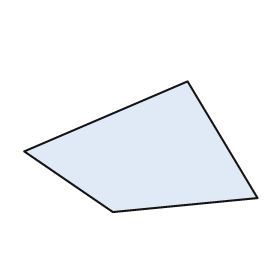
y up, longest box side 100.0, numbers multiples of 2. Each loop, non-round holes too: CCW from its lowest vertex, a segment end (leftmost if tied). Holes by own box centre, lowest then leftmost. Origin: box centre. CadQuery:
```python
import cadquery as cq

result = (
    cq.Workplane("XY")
    .moveTo(-12.0, -28.0)
    .lineTo(50.0, -22.0)
    .lineTo(20.0, 28.0)
    .lineTo(-50.0, -2.0)
    .close()
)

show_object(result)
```